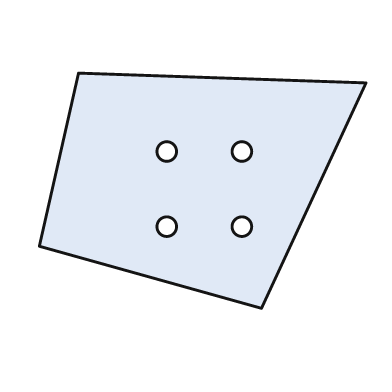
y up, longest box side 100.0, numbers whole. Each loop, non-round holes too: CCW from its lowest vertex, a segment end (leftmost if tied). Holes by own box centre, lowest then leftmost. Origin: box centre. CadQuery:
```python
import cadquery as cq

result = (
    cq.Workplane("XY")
    .moveTo(18.0, -36.0)
    .lineTo(50.0, 33.0)
    .lineTo(-38.0, 36.0)
    .lineTo(-50.0, -17.0)
    .close()
    .moveTo(-11.0, -11.0)
    .circle(3.0)
    .moveTo(12.0, -11.0)
    .circle(3.0)
    .moveTo(-11.0, 12.0)
    .circle(3.0)
    .moveTo(12.0, 12.0)
    .circle(3.0)
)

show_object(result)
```